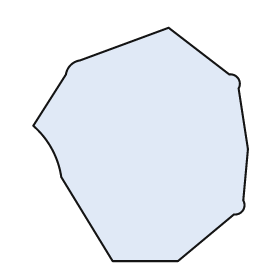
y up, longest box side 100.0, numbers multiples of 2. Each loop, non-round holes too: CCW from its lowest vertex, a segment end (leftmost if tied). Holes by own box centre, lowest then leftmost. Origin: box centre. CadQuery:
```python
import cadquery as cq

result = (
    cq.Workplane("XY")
    .moveTo(-12.0, -50.0)
    .lineTo(16.0, -50.0)
    .lineTo(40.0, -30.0)
    .threePointArc((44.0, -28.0), (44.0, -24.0))
    .lineTo(46.0, -2.0)
    .lineTo(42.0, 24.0)
    .threePointArc((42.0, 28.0), (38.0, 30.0))
    .lineTo(12.0, 50.0)
    .lineTo(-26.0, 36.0)
    .threePointArc((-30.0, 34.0), (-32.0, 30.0))
    .lineTo(-46.0, 8.0)
    .threePointArc((-38.0, -2.0), (-34.0, -14.0))
    .close()
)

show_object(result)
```